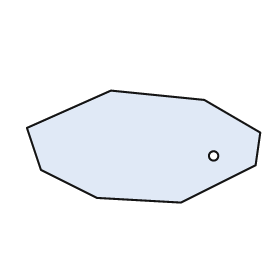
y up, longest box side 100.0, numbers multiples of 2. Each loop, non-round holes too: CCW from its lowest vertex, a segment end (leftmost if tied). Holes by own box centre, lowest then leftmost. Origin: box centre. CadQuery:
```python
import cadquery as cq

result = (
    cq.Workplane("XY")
    .moveTo(16.0, -24.0)
    .lineTo(48.0, -8.0)
    .lineTo(50.0, 6.0)
    .lineTo(26.0, 20.0)
    .lineTo(-14.0, 24.0)
    .lineTo(-50.0, 8.0)
    .lineTo(-44.0, -10.0)
    .lineTo(-20.0, -22.0)
    .close()
    .moveTo(30.0, -4.0)
    .circle(2.0)
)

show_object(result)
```